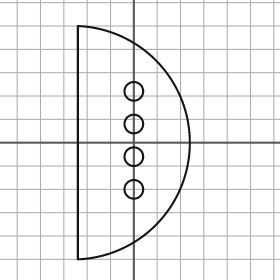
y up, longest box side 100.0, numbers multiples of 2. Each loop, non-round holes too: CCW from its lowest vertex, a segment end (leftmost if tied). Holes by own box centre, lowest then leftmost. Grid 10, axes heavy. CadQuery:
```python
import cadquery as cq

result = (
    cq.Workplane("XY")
    .moveTo(-24.0, -50.0)
    .threePointArc((24.0, 0.0), (-24.0, 50.0))
    .close()
    .moveTo(0.0, -20.0)
    .circle(4.0)
    .moveTo(0.0, -6.0)
    .circle(4.0)
    .moveTo(0.0, 8.0)
    .circle(4.0)
    .moveTo(0.0, 22.0)
    .circle(4.0)
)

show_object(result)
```